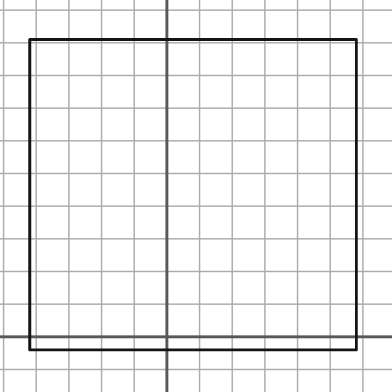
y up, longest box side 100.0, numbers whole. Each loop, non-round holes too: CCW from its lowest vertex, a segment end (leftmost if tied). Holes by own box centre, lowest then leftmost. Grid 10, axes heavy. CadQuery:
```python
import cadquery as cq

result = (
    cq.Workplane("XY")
    .moveTo(-42.0, -4.0)
    .lineTo(58.0, -4.0)
    .lineTo(58.0, 91.0)
    .lineTo(-42.0, 91.0)
    .close()
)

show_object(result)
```